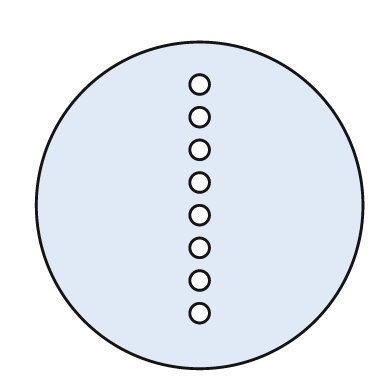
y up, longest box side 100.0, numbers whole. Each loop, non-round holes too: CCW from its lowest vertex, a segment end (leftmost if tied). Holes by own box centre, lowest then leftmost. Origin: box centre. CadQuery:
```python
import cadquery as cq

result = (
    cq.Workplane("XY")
    .moveTo(0.0, 0.0)
    .circle(50.0)
    .moveTo(0.0, -33.0)
    .circle(3.0)
    .moveTo(0.0, -23.0)
    .circle(3.0)
    .moveTo(0.0, -13.0)
    .circle(3.0)
    .moveTo(0.0, -3.0)
    .circle(3.0)
    .moveTo(0.0, 7.0)
    .circle(3.0)
    .moveTo(0.0, 17.0)
    .circle(3.0)
    .moveTo(0.0, 27.0)
    .circle(3.0)
    .moveTo(0.0, 37.0)
    .circle(3.0)
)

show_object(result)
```